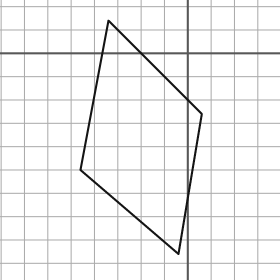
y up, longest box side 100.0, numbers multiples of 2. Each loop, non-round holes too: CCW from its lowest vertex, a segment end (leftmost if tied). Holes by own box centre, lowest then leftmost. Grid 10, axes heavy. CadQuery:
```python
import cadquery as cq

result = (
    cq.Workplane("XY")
    .moveTo(-4.0, -86.0)
    .lineTo(6.0, -26.0)
    .lineTo(-34.0, 14.0)
    .lineTo(-46.0, -50.0)
    .close()
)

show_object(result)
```